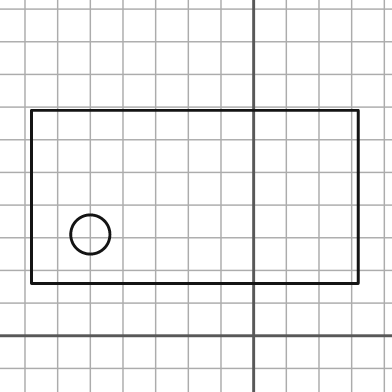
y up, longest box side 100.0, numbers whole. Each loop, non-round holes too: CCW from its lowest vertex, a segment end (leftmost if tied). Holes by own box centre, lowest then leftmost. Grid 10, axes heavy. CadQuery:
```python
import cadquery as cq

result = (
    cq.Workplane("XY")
    .moveTo(-68.0, 16.0)
    .lineTo(32.0, 16.0)
    .lineTo(32.0, 69.0)
    .lineTo(-68.0, 69.0)
    .close()
    .moveTo(-50.0, 31.0)
    .circle(6.0)
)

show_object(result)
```